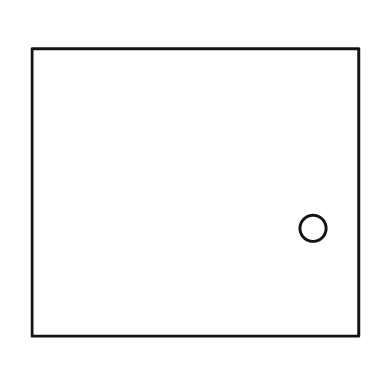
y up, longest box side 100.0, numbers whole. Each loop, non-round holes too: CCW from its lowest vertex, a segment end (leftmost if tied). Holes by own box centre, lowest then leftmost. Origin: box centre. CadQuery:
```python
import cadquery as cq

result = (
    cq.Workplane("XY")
    .moveTo(-50.0, -44.0)
    .lineTo(50.0, -44.0)
    .lineTo(50.0, 44.0)
    .lineTo(-50.0, 44.0)
    .close()
    .moveTo(36.0, -11.0)
    .circle(4.0)
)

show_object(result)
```